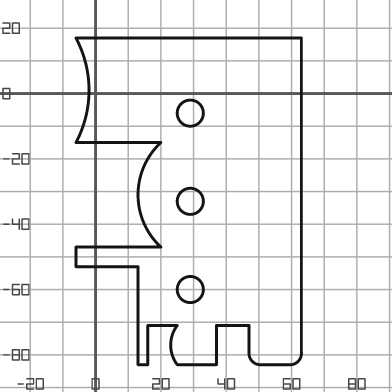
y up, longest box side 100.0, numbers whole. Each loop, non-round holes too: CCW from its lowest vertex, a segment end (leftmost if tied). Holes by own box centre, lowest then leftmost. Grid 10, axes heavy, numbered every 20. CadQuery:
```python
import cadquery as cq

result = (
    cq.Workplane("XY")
    .moveTo(13.0, -83.0)
    .lineTo(16.0, -83.0)
    .lineTo(16.0, -71.0)
    .lineTo(25.0, -71.0)
    .threePointArc((23.0, -77.0), (25.0, -83.0))
    .lineTo(37.0, -83.0)
    .lineTo(37.0, -71.0)
    .lineTo(47.0, -71.0)
    .lineTo(47.0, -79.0)
    .threePointArc((48.0, -82.0), (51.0, -83.0))
    .lineTo(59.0, -83.0)
    .threePointArc((62.0, -82.0), (63.0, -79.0))
    .lineTo(63.0, 17.0)
    .lineTo(-6.0, 17.0)
    .threePointArc((-2.0, 1.0), (-6.0, -15.0))
    .lineTo(20.0, -15.0)
    .threePointArc((13.0, -31.0), (20.0, -47.0))
    .lineTo(-6.0, -47.0)
    .lineTo(-6.0, -53.0)
    .lineTo(13.0, -53.0)
    .close()
    .moveTo(29.0, -60.0)
    .circle(4.0)
    .moveTo(29.0, -33.0)
    .circle(4.0)
    .moveTo(29.0, -6.0)
    .circle(4.0)
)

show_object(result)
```